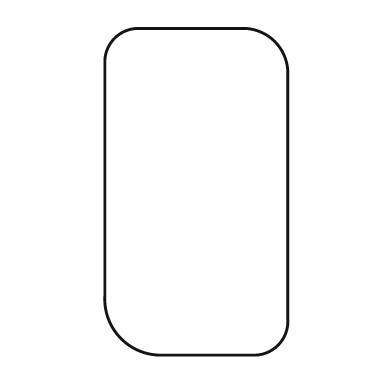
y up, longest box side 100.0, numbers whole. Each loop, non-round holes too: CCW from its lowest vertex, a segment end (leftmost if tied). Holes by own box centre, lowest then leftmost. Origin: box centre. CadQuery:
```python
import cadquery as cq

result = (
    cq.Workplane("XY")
    .moveTo(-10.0, -50.0)
    .lineTo(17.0, -50.0)
    .threePointArc((25.0, -47.0), (28.0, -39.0))
    .lineTo(28.0, 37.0)
    .threePointArc((24.0, 46.0), (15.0, 50.0))
    .lineTo(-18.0, 50.0)
    .threePointArc((-25.0, 47.0), (-28.0, 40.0))
    .lineTo(-28.0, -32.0)
    .threePointArc((-23.0, -45.0), (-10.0, -50.0))
    .close()
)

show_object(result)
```